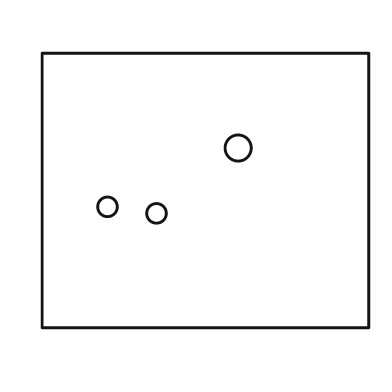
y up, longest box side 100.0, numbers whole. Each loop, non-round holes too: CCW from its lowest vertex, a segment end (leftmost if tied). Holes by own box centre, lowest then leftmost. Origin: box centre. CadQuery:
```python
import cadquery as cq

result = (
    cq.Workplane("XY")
    .moveTo(-50.0, -42.0)
    .lineTo(50.0, -42.0)
    .lineTo(50.0, 42.0)
    .lineTo(-50.0, 42.0)
    .close()
    .moveTo(-15.0, -7.0)
    .circle(3.0)
    .moveTo(-30.0, -5.0)
    .circle(3.0)
    .moveTo(10.0, 13.0)
    .circle(4.0)
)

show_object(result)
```